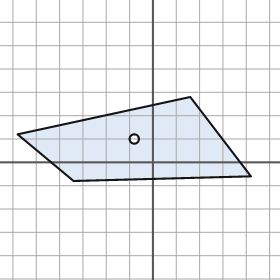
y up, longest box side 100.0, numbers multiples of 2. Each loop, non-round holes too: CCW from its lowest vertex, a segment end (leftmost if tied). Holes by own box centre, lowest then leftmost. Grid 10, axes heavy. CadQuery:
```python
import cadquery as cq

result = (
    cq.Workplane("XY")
    .moveTo(-34.0, -8.0)
    .lineTo(42.0, -6.0)
    .lineTo(16.0, 28.0)
    .lineTo(-58.0, 12.0)
    .close()
    .moveTo(-8.0, 10.0)
    .circle(2.0)
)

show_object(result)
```